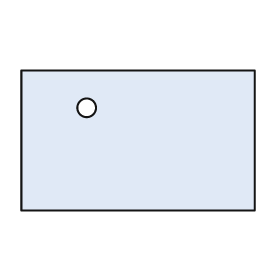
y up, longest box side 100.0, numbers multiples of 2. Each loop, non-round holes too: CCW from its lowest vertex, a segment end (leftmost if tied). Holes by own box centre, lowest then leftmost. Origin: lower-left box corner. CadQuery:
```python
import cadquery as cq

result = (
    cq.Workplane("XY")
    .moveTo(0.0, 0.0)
    .lineTo(100.0, 0.0)
    .lineTo(100.0, 60.0)
    .lineTo(0.0, 60.0)
    .close()
    .moveTo(28.0, 44.0)
    .circle(4.0)
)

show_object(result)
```